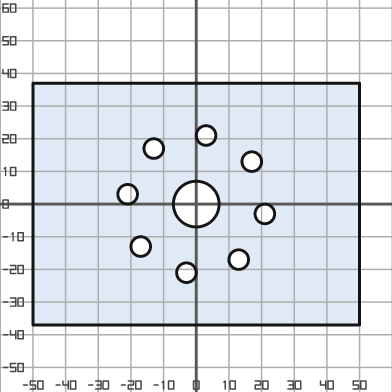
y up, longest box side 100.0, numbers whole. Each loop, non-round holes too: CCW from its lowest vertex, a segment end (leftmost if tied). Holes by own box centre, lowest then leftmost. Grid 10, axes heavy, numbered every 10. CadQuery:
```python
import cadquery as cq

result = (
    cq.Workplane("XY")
    .moveTo(-50.0, -37.0)
    .lineTo(50.0, -37.0)
    .lineTo(50.0, 37.0)
    .lineTo(-50.0, 37.0)
    .close()
    .moveTo(-3.0, -21.0)
    .circle(3.0)
    .moveTo(13.0, -17.0)
    .circle(3.0)
    .moveTo(-17.0, -13.0)
    .circle(3.0)
    .moveTo(21.0, -3.0)
    .circle(3.0)
    .moveTo(0.0, 0.0)
    .circle(7.0)
    .moveTo(-21.0, 3.0)
    .circle(3.0)
    .moveTo(17.0, 13.0)
    .circle(3.0)
    .moveTo(-13.0, 17.0)
    .circle(3.0)
    .moveTo(3.0, 21.0)
    .circle(3.0)
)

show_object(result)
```